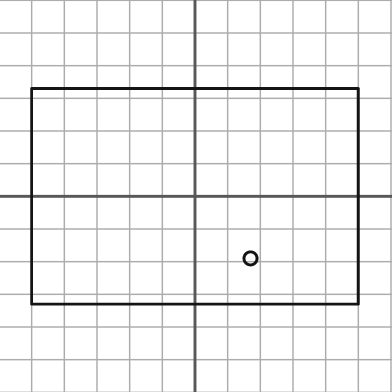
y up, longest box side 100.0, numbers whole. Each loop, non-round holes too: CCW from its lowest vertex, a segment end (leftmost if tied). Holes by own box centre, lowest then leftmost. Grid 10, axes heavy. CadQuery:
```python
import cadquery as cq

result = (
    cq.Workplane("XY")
    .moveTo(-50.0, -33.0)
    .lineTo(50.0, -33.0)
    .lineTo(50.0, 33.0)
    .lineTo(-50.0, 33.0)
    .close()
    .moveTo(17.0, -19.0)
    .circle(2.0)
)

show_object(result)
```